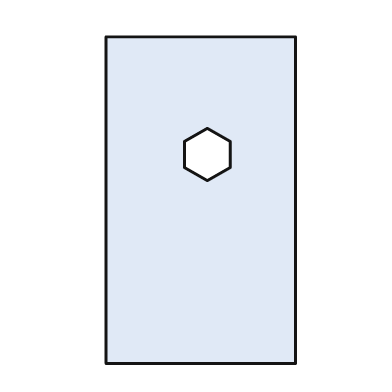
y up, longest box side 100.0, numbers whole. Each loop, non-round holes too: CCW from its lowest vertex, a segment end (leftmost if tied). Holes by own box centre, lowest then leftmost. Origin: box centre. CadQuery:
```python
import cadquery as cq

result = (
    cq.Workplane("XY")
    .moveTo(-29.0, -50.0)
    .lineTo(29.0, -50.0)
    .lineTo(29.0, 50.0)
    .lineTo(-29.0, 50.0)
    .close()
    .moveTo(2.0, 6.0)
    .lineTo(9.0, 10.0)
    .lineTo(9.0, 18.0)
    .lineTo(2.0, 22.0)
    .lineTo(-5.0, 18.0)
    .lineTo(-5.0, 10.0)
    .close()
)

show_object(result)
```